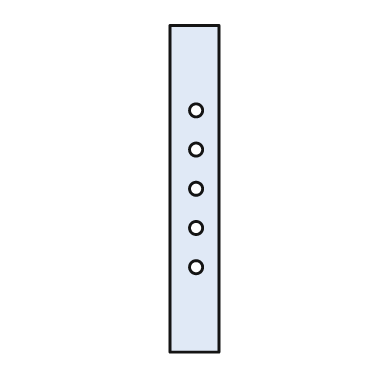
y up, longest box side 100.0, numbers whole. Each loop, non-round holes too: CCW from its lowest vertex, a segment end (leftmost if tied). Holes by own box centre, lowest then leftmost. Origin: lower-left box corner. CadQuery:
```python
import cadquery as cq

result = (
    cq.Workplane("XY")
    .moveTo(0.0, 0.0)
    .lineTo(15.0, 0.0)
    .lineTo(15.0, 100.0)
    .lineTo(0.0, 100.0)
    .close()
    .moveTo(8.0, 26.0)
    .circle(2.0)
    .moveTo(8.0, 38.0)
    .circle(2.0)
    .moveTo(8.0, 50.0)
    .circle(2.0)
    .moveTo(8.0, 62.0)
    .circle(2.0)
    .moveTo(8.0, 74.0)
    .circle(2.0)
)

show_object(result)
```